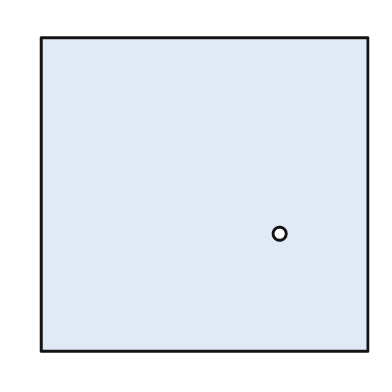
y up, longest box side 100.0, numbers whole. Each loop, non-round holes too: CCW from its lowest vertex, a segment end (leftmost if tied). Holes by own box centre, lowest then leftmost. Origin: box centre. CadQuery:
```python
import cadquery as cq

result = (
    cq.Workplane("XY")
    .moveTo(-50.0, -48.0)
    .lineTo(50.0, -48.0)
    .lineTo(50.0, 48.0)
    .lineTo(-50.0, 48.0)
    .close()
    .moveTo(23.0, -12.0)
    .circle(2.0)
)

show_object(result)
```